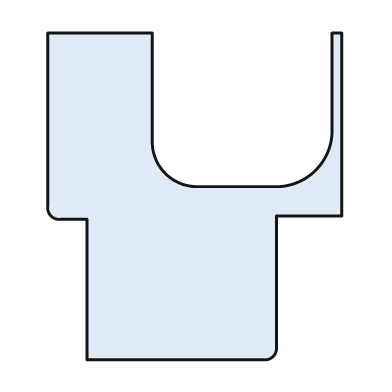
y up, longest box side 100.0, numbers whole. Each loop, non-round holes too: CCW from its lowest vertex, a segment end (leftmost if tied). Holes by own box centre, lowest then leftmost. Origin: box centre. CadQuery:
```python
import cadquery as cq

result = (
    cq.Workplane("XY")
    .moveTo(-33.0, -50.0)
    .lineTo(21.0, -50.0)
    .threePointArc((24.0, -49.0), (25.0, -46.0))
    .lineTo(25.0, -6.0)
    .lineTo(45.0, -6.0)
    .lineTo(45.0, 50.0)
    .lineTo(42.0, 50.0)
    .lineTo(42.0, 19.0)
    .threePointArc((37.0, 8.0), (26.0, 3.0))
    .lineTo(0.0, 3.0)
    .threePointArc((-9.0, 7.0), (-13.0, 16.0))
    .lineTo(-13.0, 50.0)
    .lineTo(-45.0, 50.0)
    .lineTo(-45.0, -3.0)
    .threePointArc((-44.0, -6.0), (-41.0, -7.0))
    .lineTo(-33.0, -7.0)
    .close()
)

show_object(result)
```